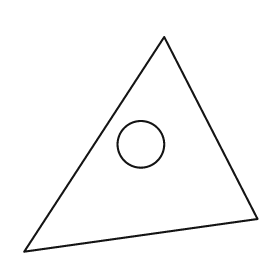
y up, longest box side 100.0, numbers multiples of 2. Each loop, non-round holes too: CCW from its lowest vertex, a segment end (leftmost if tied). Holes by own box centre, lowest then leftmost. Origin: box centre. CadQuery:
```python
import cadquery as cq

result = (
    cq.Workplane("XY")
    .moveTo(-50.0, -46.0)
    .lineTo(50.0, -32.0)
    .lineTo(10.0, 46.0)
    .close()
    .moveTo(0.0, 0.0)
    .circle(10.0)
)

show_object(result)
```